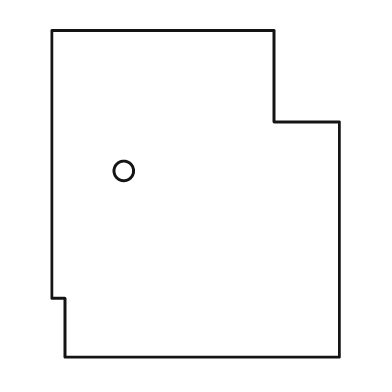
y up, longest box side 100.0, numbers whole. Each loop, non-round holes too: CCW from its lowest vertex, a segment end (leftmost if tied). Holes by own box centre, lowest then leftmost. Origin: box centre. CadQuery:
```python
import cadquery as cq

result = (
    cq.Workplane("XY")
    .moveTo(-40.0, -50.0)
    .lineTo(44.0, -50.0)
    .lineTo(44.0, 22.0)
    .lineTo(24.0, 22.0)
    .lineTo(24.0, 50.0)
    .lineTo(-44.0, 50.0)
    .lineTo(-44.0, -32.0)
    .lineTo(-40.0, -32.0)
    .close()
    .moveTo(-22.0, 7.0)
    .circle(3.0)
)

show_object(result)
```